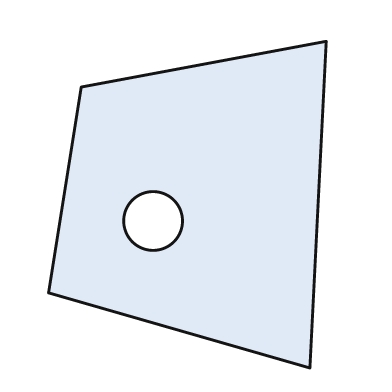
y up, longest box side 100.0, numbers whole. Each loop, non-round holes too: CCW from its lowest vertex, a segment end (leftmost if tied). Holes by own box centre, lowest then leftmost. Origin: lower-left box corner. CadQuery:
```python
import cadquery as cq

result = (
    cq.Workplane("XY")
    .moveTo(80.0, 0.0)
    .lineTo(85.0, 100.0)
    .lineTo(10.0, 86.0)
    .lineTo(0.0, 23.0)
    .close()
    .moveTo(32.0, 45.0)
    .circle(9.0)
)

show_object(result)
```